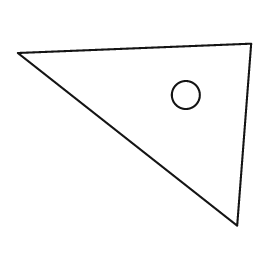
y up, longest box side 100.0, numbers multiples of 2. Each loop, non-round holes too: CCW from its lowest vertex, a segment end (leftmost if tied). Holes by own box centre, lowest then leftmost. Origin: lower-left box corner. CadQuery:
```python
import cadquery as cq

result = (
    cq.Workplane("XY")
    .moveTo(94.0, 0.0)
    .lineTo(100.0, 78.0)
    .lineTo(0.0, 74.0)
    .close()
    .moveTo(72.0, 56.0)
    .circle(6.0)
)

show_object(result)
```